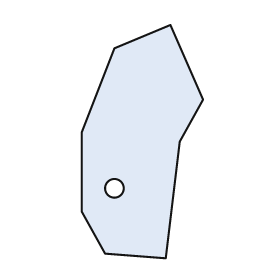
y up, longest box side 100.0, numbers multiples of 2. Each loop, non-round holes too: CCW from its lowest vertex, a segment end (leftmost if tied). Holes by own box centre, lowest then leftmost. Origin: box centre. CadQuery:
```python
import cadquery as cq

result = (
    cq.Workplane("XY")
    .moveTo(10.0, -50.0)
    .lineTo(16.0, 0.0)
    .lineTo(26.0, 18.0)
    .lineTo(12.0, 50.0)
    .lineTo(-12.0, 40.0)
    .lineTo(-26.0, 4.0)
    .lineTo(-26.0, -30.0)
    .lineTo(-16.0, -48.0)
    .close()
    .moveTo(-12.0, -20.0)
    .circle(4.0)
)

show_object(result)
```